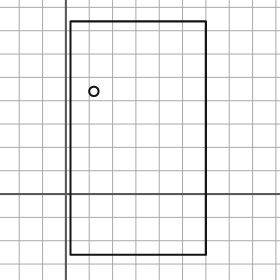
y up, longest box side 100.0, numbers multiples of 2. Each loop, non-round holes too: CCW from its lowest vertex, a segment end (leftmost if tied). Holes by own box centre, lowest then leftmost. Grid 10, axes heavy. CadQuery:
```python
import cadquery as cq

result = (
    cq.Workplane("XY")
    .moveTo(2.0, -26.0)
    .lineTo(60.0, -26.0)
    .lineTo(60.0, 74.0)
    .lineTo(2.0, 74.0)
    .close()
    .moveTo(12.0, 44.0)
    .circle(2.0)
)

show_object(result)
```